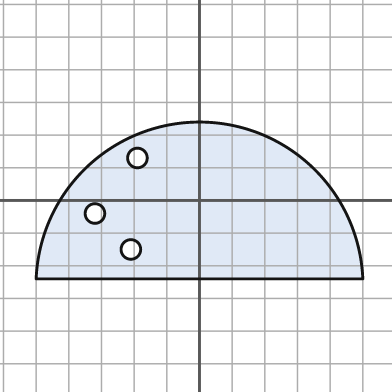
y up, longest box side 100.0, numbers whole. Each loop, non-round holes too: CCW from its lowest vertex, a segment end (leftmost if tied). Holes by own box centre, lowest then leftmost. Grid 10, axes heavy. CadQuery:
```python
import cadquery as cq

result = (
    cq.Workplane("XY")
    .moveTo(-50.0, -24.0)
    .lineTo(50.0, -24.0)
    .threePointArc((0.0, 24.0), (-50.0, -24.0))
    .close()
    .moveTo(-21.0, -15.0)
    .circle(3.0)
    .moveTo(-32.0, -4.0)
    .circle(3.0)
    .moveTo(-19.0, 13.0)
    .circle(3.0)
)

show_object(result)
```